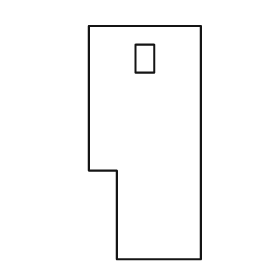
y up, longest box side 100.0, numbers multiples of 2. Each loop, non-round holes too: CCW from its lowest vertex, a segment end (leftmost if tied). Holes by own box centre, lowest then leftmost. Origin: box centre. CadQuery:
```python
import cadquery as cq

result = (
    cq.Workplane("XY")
    .moveTo(-12.0, -50.0)
    .lineTo(24.0, -50.0)
    .lineTo(24.0, 50.0)
    .lineTo(-24.0, 50.0)
    .lineTo(-24.0, -12.0)
    .lineTo(-12.0, -12.0)
    .close()
    .moveTo(-4.0, 30.0)
    .lineTo(4.0, 30.0)
    .lineTo(4.0, 42.0)
    .lineTo(-4.0, 42.0)
    .close()
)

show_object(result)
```